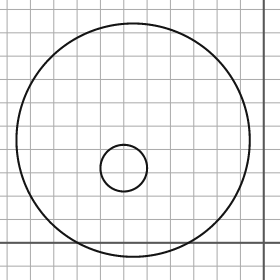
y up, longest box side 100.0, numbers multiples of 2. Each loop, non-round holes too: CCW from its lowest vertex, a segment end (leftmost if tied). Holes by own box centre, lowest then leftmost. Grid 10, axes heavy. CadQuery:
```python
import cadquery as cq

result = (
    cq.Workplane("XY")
    .moveTo(-56.0, 44.0)
    .circle(50.0)
    .moveTo(-60.0, 32.0)
    .circle(10.0)
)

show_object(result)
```